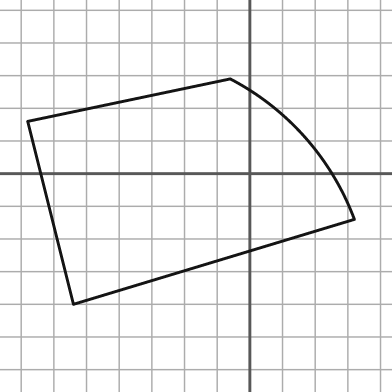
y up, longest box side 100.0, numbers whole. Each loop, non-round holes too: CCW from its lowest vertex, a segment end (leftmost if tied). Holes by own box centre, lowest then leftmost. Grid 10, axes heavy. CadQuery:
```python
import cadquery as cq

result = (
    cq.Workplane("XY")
    .moveTo(-54.0, -40.0)
    .lineTo(32.0, -14.0)
    .threePointArc((17.0, 11.0), (-6.0, 29.0))
    .lineTo(-68.0, 16.0)
    .close()
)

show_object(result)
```